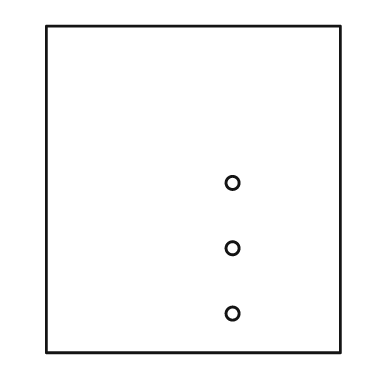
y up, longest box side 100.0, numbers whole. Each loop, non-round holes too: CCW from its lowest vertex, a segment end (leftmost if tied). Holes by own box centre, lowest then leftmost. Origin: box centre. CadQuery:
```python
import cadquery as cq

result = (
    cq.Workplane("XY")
    .moveTo(-45.0, -50.0)
    .lineTo(45.0, -50.0)
    .lineTo(45.0, 50.0)
    .lineTo(-45.0, 50.0)
    .close()
    .moveTo(12.0, -38.0)
    .circle(2.0)
    .moveTo(12.0, -18.0)
    .circle(2.0)
    .moveTo(12.0, 2.0)
    .circle(2.0)
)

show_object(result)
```